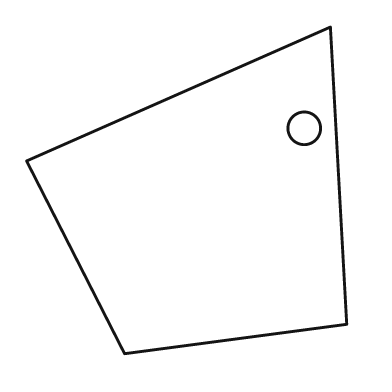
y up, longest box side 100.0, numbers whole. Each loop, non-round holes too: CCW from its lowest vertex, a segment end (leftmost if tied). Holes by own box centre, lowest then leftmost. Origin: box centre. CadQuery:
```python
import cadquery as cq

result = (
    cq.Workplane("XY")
    .moveTo(-19.0, -50.0)
    .lineTo(49.0, -41.0)
    .lineTo(44.0, 50.0)
    .lineTo(-49.0, 9.0)
    .close()
    .moveTo(36.0, 19.0)
    .circle(5.0)
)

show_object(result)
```